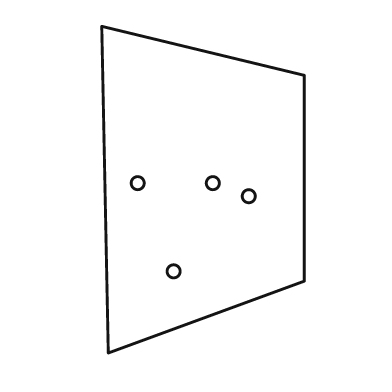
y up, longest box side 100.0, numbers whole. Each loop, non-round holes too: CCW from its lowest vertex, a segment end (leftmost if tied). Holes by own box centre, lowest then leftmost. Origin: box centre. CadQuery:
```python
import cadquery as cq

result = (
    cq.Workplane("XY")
    .moveTo(-29.0, -50.0)
    .lineTo(31.0, -28.0)
    .lineTo(31.0, 35.0)
    .lineTo(-31.0, 50.0)
    .close()
    .moveTo(-9.0, -25.0)
    .circle(2.0)
    .moveTo(14.0, -2.0)
    .circle(2.0)
    .moveTo(-20.0, 2.0)
    .circle(2.0)
    .moveTo(3.0, 2.0)
    .circle(2.0)
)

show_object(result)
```